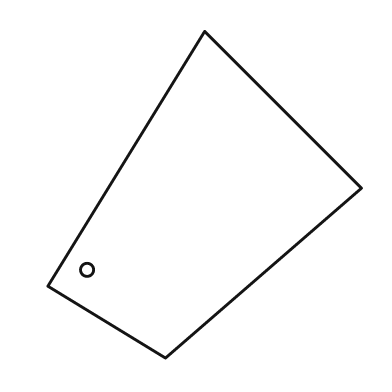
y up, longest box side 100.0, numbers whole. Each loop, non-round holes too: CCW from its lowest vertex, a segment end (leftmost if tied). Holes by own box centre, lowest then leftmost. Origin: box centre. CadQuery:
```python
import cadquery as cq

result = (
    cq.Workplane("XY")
    .moveTo(-12.0, -50.0)
    .lineTo(48.0, 2.0)
    .lineTo(0.0, 50.0)
    .lineTo(-48.0, -28.0)
    .close()
    .moveTo(-36.0, -23.0)
    .circle(2.0)
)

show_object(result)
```